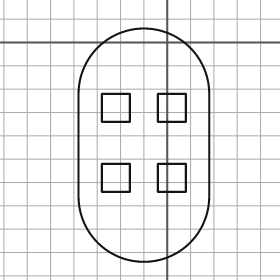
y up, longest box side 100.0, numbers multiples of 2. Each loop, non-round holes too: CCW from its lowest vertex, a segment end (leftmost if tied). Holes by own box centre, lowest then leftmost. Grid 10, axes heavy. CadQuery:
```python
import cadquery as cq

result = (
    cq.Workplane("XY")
    .moveTo(-38.0, -66.0)
    .threePointArc((-10.0, -94.0), (18.0, -66.0))
    .lineTo(18.0, -22.0)
    .threePointArc((-10.0, 6.0), (-38.0, -22.0))
    .close()
    .moveTo(-28.0, -64.0)
    .lineTo(-16.0, -64.0)
    .lineTo(-16.0, -52.0)
    .lineTo(-28.0, -52.0)
    .close()
    .moveTo(-4.0, -64.0)
    .lineTo(8.0, -64.0)
    .lineTo(8.0, -52.0)
    .lineTo(-4.0, -52.0)
    .close()
    .moveTo(-28.0, -34.0)
    .lineTo(-16.0, -34.0)
    .lineTo(-16.0, -22.0)
    .lineTo(-28.0, -22.0)
    .close()
    .moveTo(-4.0, -34.0)
    .lineTo(8.0, -34.0)
    .lineTo(8.0, -22.0)
    .lineTo(-4.0, -22.0)
    .close()
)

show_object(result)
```